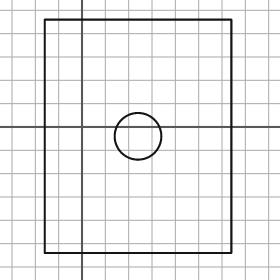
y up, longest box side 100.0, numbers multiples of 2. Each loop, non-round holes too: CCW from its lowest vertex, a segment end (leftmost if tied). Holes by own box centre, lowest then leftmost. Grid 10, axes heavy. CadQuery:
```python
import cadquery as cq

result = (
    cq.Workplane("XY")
    .moveTo(-16.0, -54.0)
    .lineTo(64.0, -54.0)
    .lineTo(64.0, 46.0)
    .lineTo(-16.0, 46.0)
    .close()
    .moveTo(24.0, -4.0)
    .circle(10.0)
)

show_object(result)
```